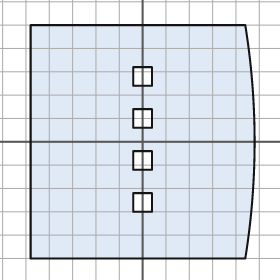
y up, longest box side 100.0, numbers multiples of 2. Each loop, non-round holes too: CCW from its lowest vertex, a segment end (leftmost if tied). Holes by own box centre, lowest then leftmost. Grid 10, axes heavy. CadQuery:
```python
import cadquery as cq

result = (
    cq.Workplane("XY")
    .moveTo(-48.0, -50.0)
    .lineTo(44.0, -50.0)
    .threePointArc((48.0, 0.0), (44.0, 50.0))
    .lineTo(-48.0, 50.0)
    .close()
    .moveTo(-4.0, -30.0)
    .lineTo(4.0, -30.0)
    .lineTo(4.0, -22.0)
    .lineTo(-4.0, -22.0)
    .close()
    .moveTo(-4.0, -12.0)
    .lineTo(4.0, -12.0)
    .lineTo(4.0, -4.0)
    .lineTo(-4.0, -4.0)
    .close()
    .moveTo(-4.0, 6.0)
    .lineTo(4.0, 6.0)
    .lineTo(4.0, 14.0)
    .lineTo(-4.0, 14.0)
    .close()
    .moveTo(-4.0, 24.0)
    .lineTo(4.0, 24.0)
    .lineTo(4.0, 32.0)
    .lineTo(-4.0, 32.0)
    .close()
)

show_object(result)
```